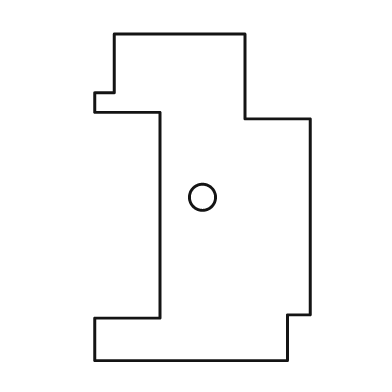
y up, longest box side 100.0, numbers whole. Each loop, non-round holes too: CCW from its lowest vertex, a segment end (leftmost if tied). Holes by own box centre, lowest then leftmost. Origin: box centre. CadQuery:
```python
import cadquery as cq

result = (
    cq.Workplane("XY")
    .moveTo(-33.0, -50.0)
    .lineTo(26.0, -50.0)
    .lineTo(26.0, -36.0)
    .lineTo(33.0, -36.0)
    .lineTo(33.0, 24.0)
    .lineTo(13.0, 24.0)
    .lineTo(13.0, 50.0)
    .lineTo(-27.0, 50.0)
    .lineTo(-27.0, 32.0)
    .lineTo(-33.0, 32.0)
    .lineTo(-33.0, 26.0)
    .lineTo(-13.0, 26.0)
    .lineTo(-13.0, -37.0)
    .lineTo(-33.0, -37.0)
    .close()
    .moveTo(0.0, 0.0)
    .circle(4.0)
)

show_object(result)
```